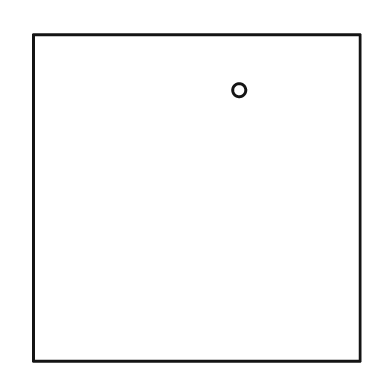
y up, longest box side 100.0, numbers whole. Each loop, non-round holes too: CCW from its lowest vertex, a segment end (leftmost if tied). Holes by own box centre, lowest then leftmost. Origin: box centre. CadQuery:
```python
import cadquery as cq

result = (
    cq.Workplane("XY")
    .moveTo(-50.0, -50.0)
    .lineTo(50.0, -50.0)
    .lineTo(50.0, 50.0)
    .lineTo(-50.0, 50.0)
    .close()
    .moveTo(13.0, 33.0)
    .circle(2.0)
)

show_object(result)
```